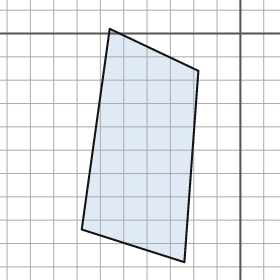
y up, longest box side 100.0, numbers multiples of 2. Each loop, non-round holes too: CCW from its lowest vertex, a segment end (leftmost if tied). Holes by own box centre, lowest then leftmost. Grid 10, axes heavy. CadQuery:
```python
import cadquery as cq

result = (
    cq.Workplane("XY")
    .moveTo(-24.0, -98.0)
    .lineTo(-18.0, -16.0)
    .lineTo(-56.0, 2.0)
    .lineTo(-68.0, -84.0)
    .close()
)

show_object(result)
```